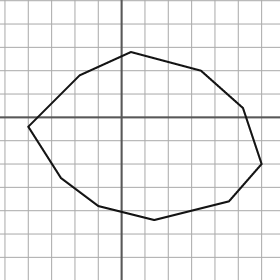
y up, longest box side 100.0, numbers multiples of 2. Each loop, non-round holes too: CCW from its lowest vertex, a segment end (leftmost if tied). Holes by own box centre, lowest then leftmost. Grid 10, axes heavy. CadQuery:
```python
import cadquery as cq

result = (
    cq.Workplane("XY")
    .moveTo(14.0, -44.0)
    .lineTo(46.0, -36.0)
    .lineTo(60.0, -20.0)
    .lineTo(52.0, 4.0)
    .lineTo(34.0, 20.0)
    .lineTo(4.0, 28.0)
    .lineTo(-18.0, 18.0)
    .lineTo(-40.0, -4.0)
    .lineTo(-26.0, -26.0)
    .lineTo(-10.0, -38.0)
    .close()
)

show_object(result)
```